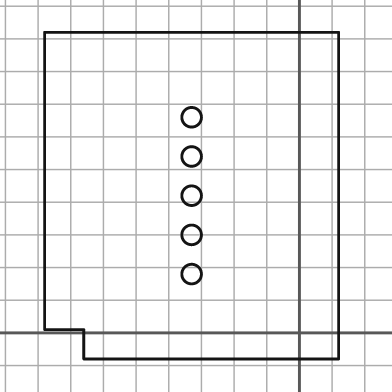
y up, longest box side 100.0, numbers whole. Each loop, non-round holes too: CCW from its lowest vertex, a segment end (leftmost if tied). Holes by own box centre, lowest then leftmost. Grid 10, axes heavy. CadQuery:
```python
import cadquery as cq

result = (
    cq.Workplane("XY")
    .moveTo(-66.0, -8.0)
    .lineTo(12.0, -8.0)
    .lineTo(12.0, 92.0)
    .lineTo(-78.0, 92.0)
    .lineTo(-78.0, 1.0)
    .lineTo(-66.0, 1.0)
    .close()
    .moveTo(-33.0, 18.0)
    .circle(3.0)
    .moveTo(-33.0, 30.0)
    .circle(3.0)
    .moveTo(-33.0, 42.0)
    .circle(3.0)
    .moveTo(-33.0, 54.0)
    .circle(3.0)
    .moveTo(-33.0, 66.0)
    .circle(3.0)
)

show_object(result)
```